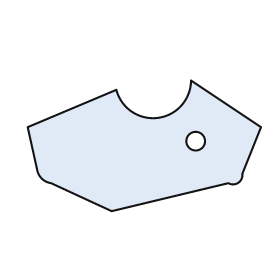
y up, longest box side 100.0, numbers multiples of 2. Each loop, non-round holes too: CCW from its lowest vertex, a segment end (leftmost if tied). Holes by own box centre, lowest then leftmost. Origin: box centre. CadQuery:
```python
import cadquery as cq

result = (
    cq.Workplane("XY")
    .moveTo(-14.0, -28.0)
    .lineTo(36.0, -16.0)
    .threePointArc((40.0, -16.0), (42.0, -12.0))
    .lineTo(50.0, 8.0)
    .lineTo(20.0, 28.0)
    .threePointArc((6.0, 12.0), (-12.0, 24.0))
    .lineTo(-50.0, 8.0)
    .lineTo(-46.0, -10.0)
    .threePointArc((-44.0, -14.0), (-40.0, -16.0))
    .close()
    .moveTo(22.0, 2.0)
    .circle(4.0)
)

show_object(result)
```